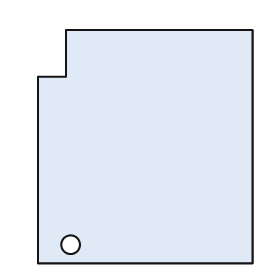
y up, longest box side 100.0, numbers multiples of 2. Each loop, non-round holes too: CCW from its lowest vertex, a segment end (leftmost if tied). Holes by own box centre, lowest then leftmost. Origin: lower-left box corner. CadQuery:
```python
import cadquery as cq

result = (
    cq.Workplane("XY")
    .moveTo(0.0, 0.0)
    .lineTo(92.0, 0.0)
    .lineTo(92.0, 100.0)
    .lineTo(12.0, 100.0)
    .lineTo(12.0, 80.0)
    .lineTo(0.0, 80.0)
    .close()
    .moveTo(14.0, 8.0)
    .circle(4.0)
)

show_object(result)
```